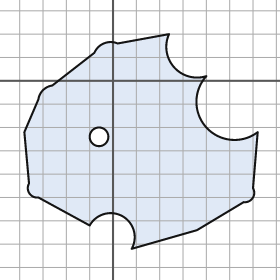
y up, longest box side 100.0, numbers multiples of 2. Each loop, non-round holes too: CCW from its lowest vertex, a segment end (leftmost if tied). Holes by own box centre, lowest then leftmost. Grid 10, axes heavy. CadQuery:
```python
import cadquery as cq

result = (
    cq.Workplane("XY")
    .moveTo(8.0, -72.0)
    .lineTo(36.0, -64.0)
    .lineTo(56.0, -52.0)
    .threePointArc((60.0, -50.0), (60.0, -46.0))
    .lineTo(62.0, -22.0)
    .threePointArc((40.0, -20.0), (40.0, 2.0))
    .threePointArc((26.0, 6.0), (24.0, 20.0))
    .lineTo(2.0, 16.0)
    .threePointArc((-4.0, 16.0), (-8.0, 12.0))
    .lineTo(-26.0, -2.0)
    .threePointArc((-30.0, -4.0), (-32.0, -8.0))
    .lineTo(-38.0, -22.0)
    .lineTo(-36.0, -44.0)
    .threePointArc((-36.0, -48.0), (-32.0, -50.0))
    .lineTo(-10.0, -62.0)
    .threePointArc((4.0, -58.0), (8.0, -72.0))
    .close()
    .moveTo(-6.0, -24.0)
    .circle(4.0)
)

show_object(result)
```